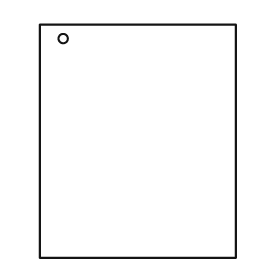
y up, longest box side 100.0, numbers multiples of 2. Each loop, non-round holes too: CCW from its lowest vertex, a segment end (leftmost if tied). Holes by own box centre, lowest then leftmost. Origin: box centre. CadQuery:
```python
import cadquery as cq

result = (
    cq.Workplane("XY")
    .moveTo(-42.0, -50.0)
    .lineTo(42.0, -50.0)
    .lineTo(42.0, 50.0)
    .lineTo(-42.0, 50.0)
    .close()
    .moveTo(-32.0, 44.0)
    .circle(2.0)
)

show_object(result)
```